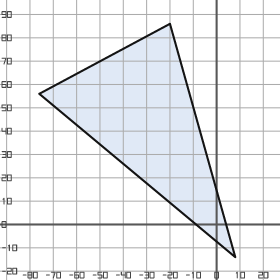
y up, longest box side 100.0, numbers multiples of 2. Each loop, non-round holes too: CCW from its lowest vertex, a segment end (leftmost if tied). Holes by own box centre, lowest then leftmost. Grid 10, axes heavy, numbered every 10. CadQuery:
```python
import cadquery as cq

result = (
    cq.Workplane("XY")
    .moveTo(8.0, -14.0)
    .lineTo(-20.0, 86.0)
    .lineTo(-76.0, 56.0)
    .close()
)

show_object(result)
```